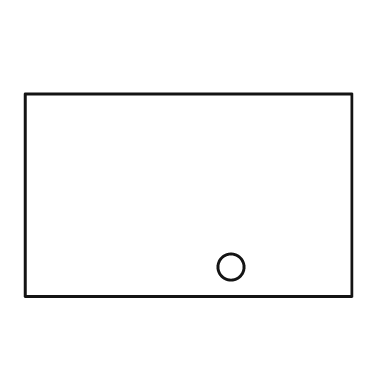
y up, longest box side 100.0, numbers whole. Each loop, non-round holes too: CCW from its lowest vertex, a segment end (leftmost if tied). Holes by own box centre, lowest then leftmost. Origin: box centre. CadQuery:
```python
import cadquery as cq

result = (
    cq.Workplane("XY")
    .moveTo(-50.0, -31.0)
    .lineTo(50.0, -31.0)
    .lineTo(50.0, 31.0)
    .lineTo(-50.0, 31.0)
    .close()
    .moveTo(13.0, -22.0)
    .circle(4.0)
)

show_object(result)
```